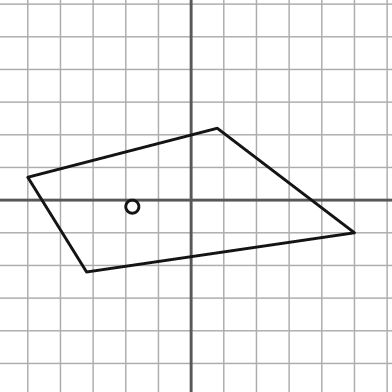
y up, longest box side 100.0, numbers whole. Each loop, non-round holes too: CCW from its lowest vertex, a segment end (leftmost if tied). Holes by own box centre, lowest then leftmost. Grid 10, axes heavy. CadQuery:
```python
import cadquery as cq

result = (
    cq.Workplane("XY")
    .moveTo(-32.0, -22.0)
    .lineTo(50.0, -10.0)
    .lineTo(8.0, 22.0)
    .lineTo(-50.0, 7.0)
    .close()
    .moveTo(-18.0, -2.0)
    .circle(2.0)
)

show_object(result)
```